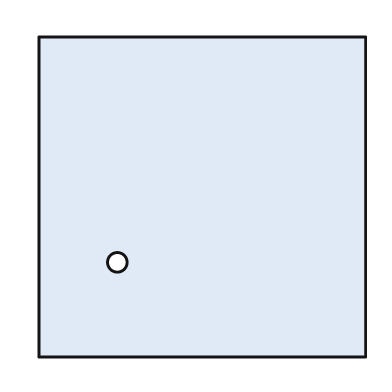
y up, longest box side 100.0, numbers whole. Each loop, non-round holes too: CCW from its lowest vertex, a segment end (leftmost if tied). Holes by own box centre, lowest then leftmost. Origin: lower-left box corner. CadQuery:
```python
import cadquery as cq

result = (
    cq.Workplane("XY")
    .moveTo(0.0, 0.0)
    .lineTo(100.0, 0.0)
    .lineTo(100.0, 98.0)
    .lineTo(0.0, 98.0)
    .close()
    .moveTo(24.0, 29.0)
    .circle(3.0)
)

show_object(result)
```